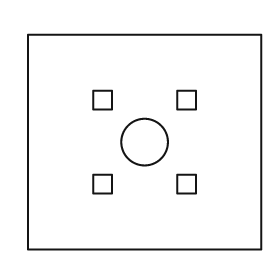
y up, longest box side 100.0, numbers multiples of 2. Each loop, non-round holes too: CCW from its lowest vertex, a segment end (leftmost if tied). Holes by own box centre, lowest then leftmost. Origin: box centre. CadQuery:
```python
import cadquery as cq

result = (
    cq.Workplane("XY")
    .moveTo(-50.0, -46.0)
    .lineTo(50.0, -46.0)
    .lineTo(50.0, 46.0)
    .lineTo(-50.0, 46.0)
    .close()
    .moveTo(-22.0, -22.0)
    .lineTo(-14.0, -22.0)
    .lineTo(-14.0, -14.0)
    .lineTo(-22.0, -14.0)
    .close()
    .moveTo(14.0, -22.0)
    .lineTo(22.0, -22.0)
    .lineTo(22.0, -14.0)
    .lineTo(14.0, -14.0)
    .close()
    .moveTo(0.0, 0.0)
    .circle(10.0)
    .moveTo(-22.0, 14.0)
    .lineTo(-14.0, 14.0)
    .lineTo(-14.0, 22.0)
    .lineTo(-22.0, 22.0)
    .close()
    .moveTo(14.0, 14.0)
    .lineTo(22.0, 14.0)
    .lineTo(22.0, 22.0)
    .lineTo(14.0, 22.0)
    .close()
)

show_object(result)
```